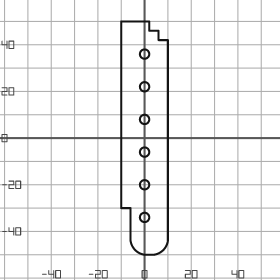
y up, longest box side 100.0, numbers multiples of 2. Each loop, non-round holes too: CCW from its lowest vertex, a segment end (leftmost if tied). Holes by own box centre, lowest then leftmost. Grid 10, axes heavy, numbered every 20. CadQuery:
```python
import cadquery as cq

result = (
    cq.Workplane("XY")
    .moveTo(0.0, -50.0)
    .lineTo(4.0, -50.0)
    .threePointArc((8.0, -48.0), (10.0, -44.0))
    .lineTo(10.0, 42.0)
    .lineTo(6.0, 42.0)
    .lineTo(6.0, 46.0)
    .lineTo(2.0, 46.0)
    .lineTo(2.0, 50.0)
    .lineTo(-10.0, 50.0)
    .lineTo(-10.0, -30.0)
    .lineTo(-6.0, -30.0)
    .lineTo(-6.0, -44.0)
    .threePointArc((-4.0, -48.0), (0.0, -50.0))
    .close()
    .moveTo(0.0, -34.0)
    .circle(2.0)
    .moveTo(0.0, -20.0)
    .circle(2.0)
    .moveTo(0.0, -6.0)
    .circle(2.0)
    .moveTo(0.0, 8.0)
    .circle(2.0)
    .moveTo(0.0, 22.0)
    .circle(2.0)
    .moveTo(0.0, 36.0)
    .circle(2.0)
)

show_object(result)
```